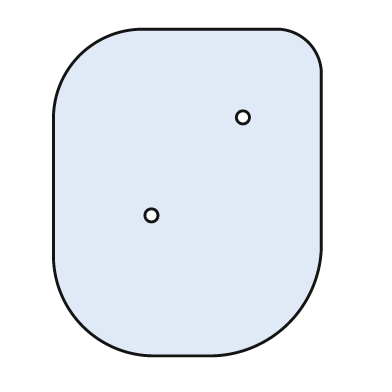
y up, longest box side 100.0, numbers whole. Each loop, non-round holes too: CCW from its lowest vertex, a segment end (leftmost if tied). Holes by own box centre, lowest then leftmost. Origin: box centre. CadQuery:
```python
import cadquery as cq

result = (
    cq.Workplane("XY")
    .moveTo(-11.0, -50.0)
    .lineTo(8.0, -50.0)
    .threePointArc((31.0, -40.0), (41.0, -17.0))
    .lineTo(41.0, 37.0)
    .threePointArc((37.0, 46.0), (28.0, 50.0))
    .lineTo(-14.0, 50.0)
    .threePointArc((-33.0, 42.0), (-41.0, 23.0))
    .lineTo(-41.0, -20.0)
    .threePointArc((-32.0, -41.0), (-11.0, -50.0))
    .close()
    .moveTo(-11.0, -7.0)
    .circle(2.0)
    .moveTo(17.0, 23.0)
    .circle(2.0)
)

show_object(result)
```